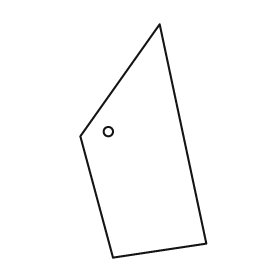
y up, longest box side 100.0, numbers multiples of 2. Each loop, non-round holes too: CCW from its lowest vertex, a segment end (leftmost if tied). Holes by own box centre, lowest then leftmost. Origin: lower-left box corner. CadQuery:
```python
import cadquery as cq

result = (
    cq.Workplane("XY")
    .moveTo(14.0, 0.0)
    .lineTo(54.0, 6.0)
    .lineTo(34.0, 100.0)
    .lineTo(0.0, 52.0)
    .close()
    .moveTo(12.0, 54.0)
    .circle(2.0)
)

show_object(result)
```